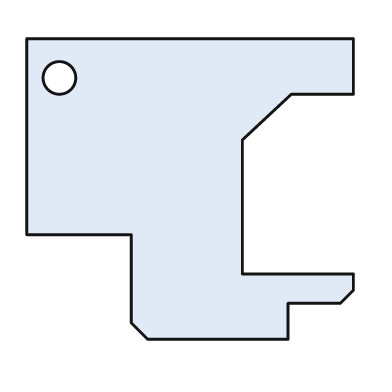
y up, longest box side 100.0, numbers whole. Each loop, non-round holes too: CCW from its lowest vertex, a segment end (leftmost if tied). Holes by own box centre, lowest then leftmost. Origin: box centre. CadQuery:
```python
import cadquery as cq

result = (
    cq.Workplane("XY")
    .moveTo(-13.0, -46.0)
    .lineTo(30.0, -46.0)
    .lineTo(30.0, -35.0)
    .lineTo(46.0, -35.0)
    .lineTo(50.0, -31.0)
    .lineTo(50.0, -26.0)
    .lineTo(16.0, -26.0)
    .lineTo(16.0, 15.0)
    .lineTo(31.0, 29.0)
    .lineTo(50.0, 29.0)
    .lineTo(50.0, 46.0)
    .lineTo(-50.0, 46.0)
    .lineTo(-50.0, -14.0)
    .lineTo(-18.0, -14.0)
    .lineTo(-18.0, -41.0)
    .close()
    .moveTo(-40.0, 34.0)
    .circle(5.0)
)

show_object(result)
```